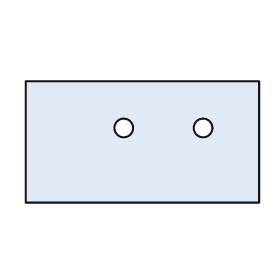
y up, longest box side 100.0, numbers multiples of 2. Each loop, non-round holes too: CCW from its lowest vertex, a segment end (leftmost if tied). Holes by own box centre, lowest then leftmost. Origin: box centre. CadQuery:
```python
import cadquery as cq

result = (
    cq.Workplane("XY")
    .moveTo(-50.0, -26.0)
    .lineTo(50.0, -26.0)
    .lineTo(50.0, 26.0)
    .lineTo(-50.0, 26.0)
    .close()
    .moveTo(-8.0, 6.0)
    .circle(4.0)
    .moveTo(26.0, 6.0)
    .circle(4.0)
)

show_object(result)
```